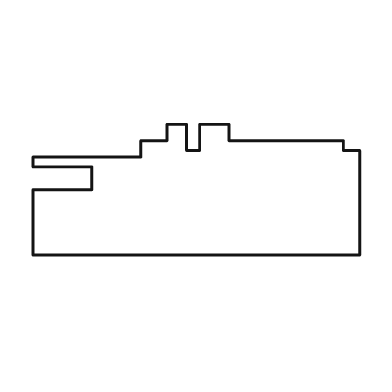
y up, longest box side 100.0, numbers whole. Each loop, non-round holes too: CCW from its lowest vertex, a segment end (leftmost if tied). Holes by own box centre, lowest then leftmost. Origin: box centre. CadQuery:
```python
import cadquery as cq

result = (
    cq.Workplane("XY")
    .moveTo(-50.0, -20.0)
    .lineTo(50.0, -20.0)
    .lineTo(50.0, 12.0)
    .lineTo(45.0, 12.0)
    .lineTo(45.0, 15.0)
    .lineTo(10.0, 15.0)
    .lineTo(10.0, 20.0)
    .lineTo(1.0, 20.0)
    .lineTo(1.0, 12.0)
    .lineTo(-3.0, 12.0)
    .lineTo(-3.0, 20.0)
    .lineTo(-9.0, 20.0)
    .lineTo(-9.0, 15.0)
    .lineTo(-17.0, 15.0)
    .lineTo(-17.0, 10.0)
    .lineTo(-50.0, 10.0)
    .lineTo(-50.0, 7.0)
    .lineTo(-32.0, 7.0)
    .lineTo(-32.0, 0.0)
    .lineTo(-50.0, 0.0)
    .close()
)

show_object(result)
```